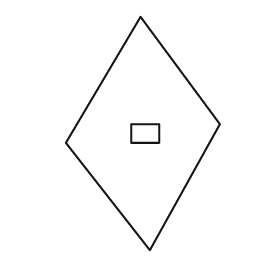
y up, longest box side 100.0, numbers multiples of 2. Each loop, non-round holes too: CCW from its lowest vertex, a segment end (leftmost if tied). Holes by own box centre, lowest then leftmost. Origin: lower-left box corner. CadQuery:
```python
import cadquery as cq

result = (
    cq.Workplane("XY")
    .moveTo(36.0, 0.0)
    .lineTo(66.0, 54.0)
    .lineTo(32.0, 100.0)
    .lineTo(0.0, 46.0)
    .close()
    .moveTo(28.0, 46.0)
    .lineTo(40.0, 46.0)
    .lineTo(40.0, 54.0)
    .lineTo(28.0, 54.0)
    .close()
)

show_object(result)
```